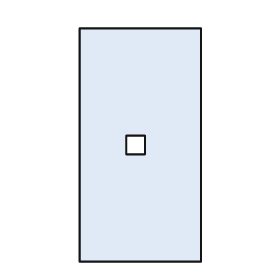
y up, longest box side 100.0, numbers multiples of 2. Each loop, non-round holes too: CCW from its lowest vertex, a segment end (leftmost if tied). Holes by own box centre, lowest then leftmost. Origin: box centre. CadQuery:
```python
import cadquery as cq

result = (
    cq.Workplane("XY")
    .moveTo(-26.0, -50.0)
    .lineTo(26.0, -50.0)
    .lineTo(26.0, 50.0)
    .lineTo(-26.0, 50.0)
    .close()
    .moveTo(-6.0, -4.0)
    .lineTo(2.0, -4.0)
    .lineTo(2.0, 4.0)
    .lineTo(-6.0, 4.0)
    .close()
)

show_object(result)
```